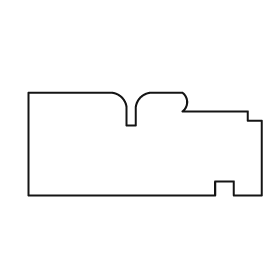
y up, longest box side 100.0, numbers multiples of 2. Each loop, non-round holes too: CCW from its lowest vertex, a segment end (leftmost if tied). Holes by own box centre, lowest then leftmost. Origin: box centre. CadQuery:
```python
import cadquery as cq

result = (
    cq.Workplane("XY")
    .moveTo(-50.0, -22.0)
    .lineTo(30.0, -22.0)
    .lineTo(30.0, -16.0)
    .lineTo(38.0, -16.0)
    .lineTo(38.0, -22.0)
    .lineTo(50.0, -22.0)
    .lineTo(50.0, 10.0)
    .lineTo(44.0, 10.0)
    .lineTo(44.0, 14.0)
    .lineTo(16.0, 14.0)
    .threePointArc((18.0, 18.0), (16.0, 22.0))
    .lineTo(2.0, 22.0)
    .threePointArc((-2.0, 20.0), (-4.0, 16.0))
    .lineTo(-4.0, 8.0)
    .lineTo(-8.0, 8.0)
    .lineTo(-8.0, 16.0)
    .threePointArc((-10.0, 20.0), (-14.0, 22.0))
    .lineTo(-50.0, 22.0)
    .close()
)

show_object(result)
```